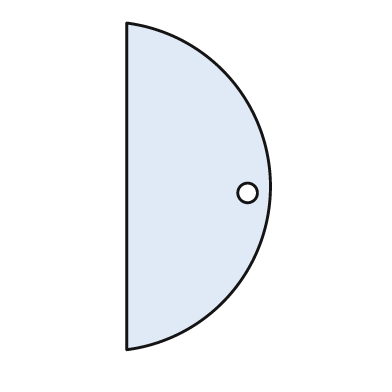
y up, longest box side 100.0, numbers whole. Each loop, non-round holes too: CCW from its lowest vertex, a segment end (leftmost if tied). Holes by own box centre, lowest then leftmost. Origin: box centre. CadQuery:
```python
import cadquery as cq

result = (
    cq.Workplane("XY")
    .moveTo(-22.0, -50.0)
    .threePointArc((22.0, 0.0), (-22.0, 50.0))
    .close()
    .moveTo(15.0, -2.0)
    .circle(3.0)
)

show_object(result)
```